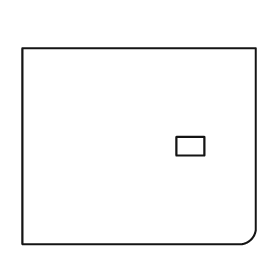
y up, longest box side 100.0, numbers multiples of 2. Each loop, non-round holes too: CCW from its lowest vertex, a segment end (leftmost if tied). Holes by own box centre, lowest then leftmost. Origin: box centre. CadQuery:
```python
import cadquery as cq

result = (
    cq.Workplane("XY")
    .moveTo(-50.0, -42.0)
    .lineTo(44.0, -42.0)
    .threePointArc((48.0, -40.0), (50.0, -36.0))
    .lineTo(50.0, 42.0)
    .lineTo(-50.0, 42.0)
    .close()
    .moveTo(16.0, -4.0)
    .lineTo(28.0, -4.0)
    .lineTo(28.0, 4.0)
    .lineTo(16.0, 4.0)
    .close()
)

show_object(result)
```